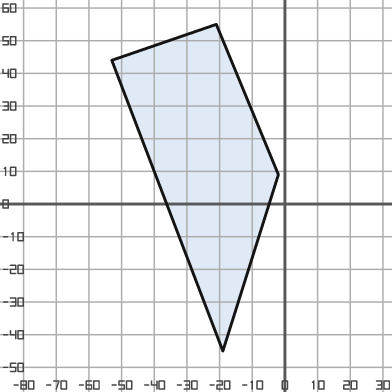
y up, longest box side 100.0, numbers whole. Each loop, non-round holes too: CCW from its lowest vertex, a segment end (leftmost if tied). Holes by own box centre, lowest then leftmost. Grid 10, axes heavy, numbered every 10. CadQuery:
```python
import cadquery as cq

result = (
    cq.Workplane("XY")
    .moveTo(-19.0, -45.0)
    .lineTo(-2.0, 9.0)
    .lineTo(-21.0, 55.0)
    .lineTo(-53.0, 44.0)
    .close()
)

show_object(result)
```